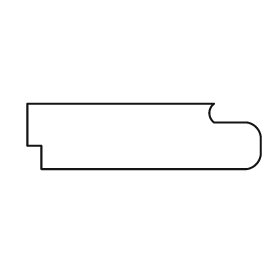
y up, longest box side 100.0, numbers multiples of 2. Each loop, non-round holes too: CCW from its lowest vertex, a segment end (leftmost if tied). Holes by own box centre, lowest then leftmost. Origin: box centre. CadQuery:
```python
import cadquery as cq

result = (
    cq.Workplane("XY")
    .moveTo(-44.0, -14.0)
    .lineTo(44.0, -14.0)
    .threePointArc((48.0, -12.0), (50.0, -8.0))
    .lineTo(50.0, 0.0)
    .threePointArc((48.0, 4.0), (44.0, 6.0))
    .lineTo(30.0, 6.0)
    .threePointArc((28.0, 10.0), (30.0, 14.0))
    .lineTo(-50.0, 14.0)
    .lineTo(-50.0, -4.0)
    .lineTo(-44.0, -4.0)
    .close()
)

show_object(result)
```